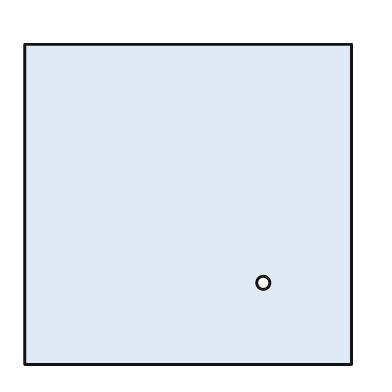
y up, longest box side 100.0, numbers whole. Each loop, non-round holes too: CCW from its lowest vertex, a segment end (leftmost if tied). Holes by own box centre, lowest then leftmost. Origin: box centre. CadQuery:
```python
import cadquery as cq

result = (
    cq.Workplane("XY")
    .moveTo(-50.0, -49.0)
    .lineTo(50.0, -49.0)
    .lineTo(50.0, 49.0)
    .lineTo(-50.0, 49.0)
    .close()
    .moveTo(23.0, -24.0)
    .circle(2.0)
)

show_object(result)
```